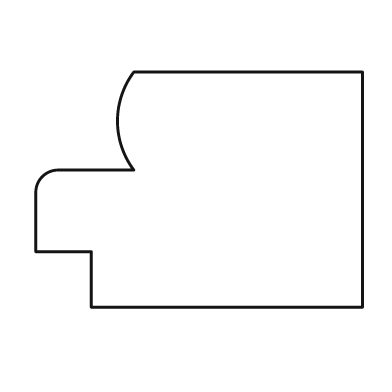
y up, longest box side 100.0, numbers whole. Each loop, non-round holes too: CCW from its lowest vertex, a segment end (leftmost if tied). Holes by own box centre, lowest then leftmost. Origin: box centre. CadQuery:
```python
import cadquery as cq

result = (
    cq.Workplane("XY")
    .moveTo(-33.0, -36.0)
    .lineTo(50.0, -36.0)
    .lineTo(50.0, 36.0)
    .lineTo(-20.0, 36.0)
    .threePointArc((-25.0, 21.0), (-20.0, 6.0))
    .lineTo(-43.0, 6.0)
    .threePointArc((-48.0, 4.0), (-50.0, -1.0))
    .lineTo(-50.0, -19.0)
    .lineTo(-33.0, -19.0)
    .close()
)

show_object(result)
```